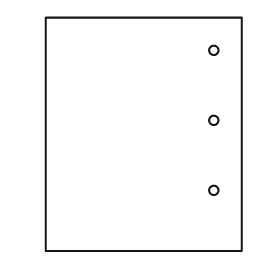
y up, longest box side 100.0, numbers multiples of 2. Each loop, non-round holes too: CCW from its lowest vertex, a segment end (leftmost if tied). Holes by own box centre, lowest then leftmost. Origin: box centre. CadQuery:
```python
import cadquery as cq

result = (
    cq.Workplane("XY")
    .moveTo(-42.0, -50.0)
    .lineTo(42.0, -50.0)
    .lineTo(42.0, 50.0)
    .lineTo(-42.0, 50.0)
    .close()
    .moveTo(30.0, -24.0)
    .circle(2.0)
    .moveTo(30.0, 6.0)
    .circle(2.0)
    .moveTo(30.0, 36.0)
    .circle(2.0)
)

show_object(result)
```